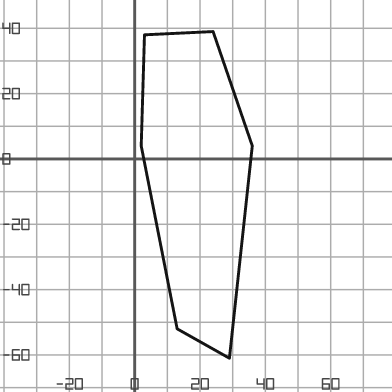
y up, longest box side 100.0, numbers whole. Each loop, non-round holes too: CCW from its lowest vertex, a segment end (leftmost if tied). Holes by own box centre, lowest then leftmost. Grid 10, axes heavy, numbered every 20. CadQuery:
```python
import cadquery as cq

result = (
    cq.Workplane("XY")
    .moveTo(29.0, -61.0)
    .lineTo(36.0, 4.0)
    .lineTo(24.0, 39.0)
    .lineTo(3.0, 38.0)
    .lineTo(2.0, 4.0)
    .lineTo(13.0, -52.0)
    .close()
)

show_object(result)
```